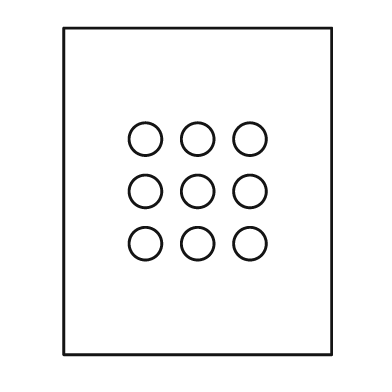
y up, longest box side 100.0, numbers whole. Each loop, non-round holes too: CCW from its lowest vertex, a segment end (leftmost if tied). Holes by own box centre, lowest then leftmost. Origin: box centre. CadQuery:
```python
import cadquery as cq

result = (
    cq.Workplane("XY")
    .moveTo(-41.0, -50.0)
    .lineTo(41.0, -50.0)
    .lineTo(41.0, 50.0)
    .lineTo(-41.0, 50.0)
    .close()
    .moveTo(-16.0, -16.0)
    .circle(5.0)
    .moveTo(0.0, -16.0)
    .circle(5.0)
    .moveTo(16.0, -16.0)
    .circle(5.0)
    .moveTo(-16.0, 0.0)
    .circle(5.0)
    .moveTo(0.0, 0.0)
    .circle(5.0)
    .moveTo(16.0, 0.0)
    .circle(5.0)
    .moveTo(-16.0, 16.0)
    .circle(5.0)
    .moveTo(0.0, 16.0)
    .circle(5.0)
    .moveTo(16.0, 16.0)
    .circle(5.0)
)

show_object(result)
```